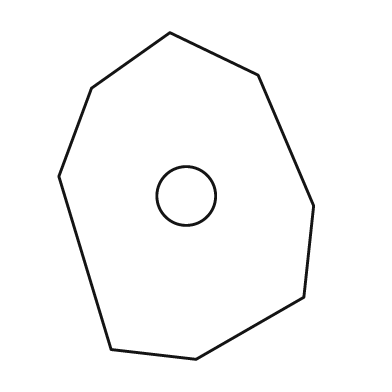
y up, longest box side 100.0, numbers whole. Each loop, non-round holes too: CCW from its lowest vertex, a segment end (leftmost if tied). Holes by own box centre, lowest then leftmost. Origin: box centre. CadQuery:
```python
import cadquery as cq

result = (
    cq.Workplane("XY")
    .moveTo(3.0, -50.0)
    .lineTo(36.0, -31.0)
    .lineTo(39.0, -3.0)
    .lineTo(22.0, 37.0)
    .lineTo(-5.0, 50.0)
    .lineTo(-29.0, 33.0)
    .lineTo(-39.0, 6.0)
    .lineTo(-23.0, -47.0)
    .close()
    .moveTo(0.0, 0.0)
    .circle(9.0)
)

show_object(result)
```